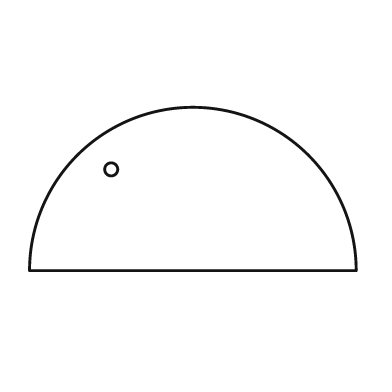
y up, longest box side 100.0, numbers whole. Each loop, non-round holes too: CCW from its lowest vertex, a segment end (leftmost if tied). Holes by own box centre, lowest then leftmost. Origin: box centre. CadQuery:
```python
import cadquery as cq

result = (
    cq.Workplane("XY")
    .moveTo(-50.0, -25.0)
    .lineTo(50.0, -25.0)
    .threePointArc((0.0, 25.0), (-50.0, -25.0))
    .close()
    .moveTo(-25.0, 6.0)
    .circle(2.0)
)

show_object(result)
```